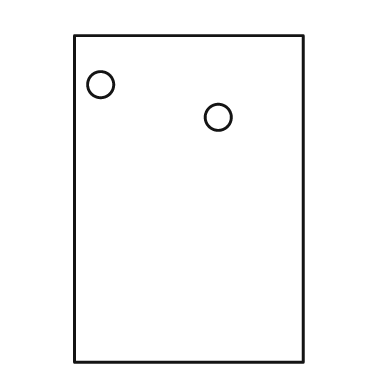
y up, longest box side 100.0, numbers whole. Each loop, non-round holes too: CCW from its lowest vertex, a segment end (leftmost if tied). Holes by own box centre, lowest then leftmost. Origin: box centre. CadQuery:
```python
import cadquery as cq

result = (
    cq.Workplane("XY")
    .moveTo(-35.0, -50.0)
    .lineTo(35.0, -50.0)
    .lineTo(35.0, 50.0)
    .lineTo(-35.0, 50.0)
    .close()
    .moveTo(9.0, 25.0)
    .circle(4.0)
    .moveTo(-27.0, 35.0)
    .circle(4.0)
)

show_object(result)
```